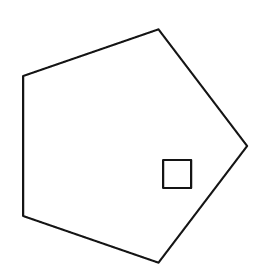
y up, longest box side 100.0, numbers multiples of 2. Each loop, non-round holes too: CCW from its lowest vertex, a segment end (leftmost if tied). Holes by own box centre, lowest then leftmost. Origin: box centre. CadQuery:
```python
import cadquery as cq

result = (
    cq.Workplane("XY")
    .moveTo(10.0, -50.0)
    .lineTo(48.0, 0.0)
    .lineTo(10.0, 50.0)
    .lineTo(-48.0, 30.0)
    .lineTo(-48.0, -30.0)
    .close()
    .moveTo(12.0, -18.0)
    .lineTo(24.0, -18.0)
    .lineTo(24.0, -6.0)
    .lineTo(12.0, -6.0)
    .close()
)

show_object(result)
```